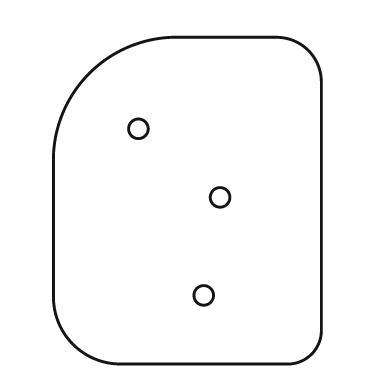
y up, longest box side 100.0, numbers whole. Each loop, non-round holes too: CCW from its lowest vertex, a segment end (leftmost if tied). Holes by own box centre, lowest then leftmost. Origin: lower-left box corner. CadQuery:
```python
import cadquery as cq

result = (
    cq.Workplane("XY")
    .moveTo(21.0, 0.0)
    .lineTo(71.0, 0.0)
    .threePointArc((79.0, 3.0), (82.0, 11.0))
    .lineTo(82.0, 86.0)
    .threePointArc((78.0, 96.0), (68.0, 100.0))
    .lineTo(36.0, 100.0)
    .threePointArc((11.0, 89.0), (0.0, 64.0))
    .lineTo(0.0, 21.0)
    .threePointArc((6.0, 6.0), (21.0, 0.0))
    .close()
    .moveTo(46.0, 21.0)
    .circle(3.0)
    .moveTo(51.0, 51.0)
    .circle(3.0)
    .moveTo(26.0, 72.0)
    .circle(3.0)
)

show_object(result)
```